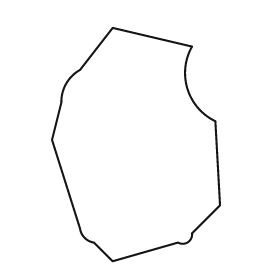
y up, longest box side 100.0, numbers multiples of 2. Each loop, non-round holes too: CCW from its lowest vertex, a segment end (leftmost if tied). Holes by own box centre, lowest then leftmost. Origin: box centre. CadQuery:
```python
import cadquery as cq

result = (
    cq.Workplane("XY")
    .moveTo(-10.0, -50.0)
    .lineTo(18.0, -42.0)
    .threePointArc((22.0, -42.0), (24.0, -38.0))
    .lineTo(36.0, -26.0)
    .lineTo(34.0, 10.0)
    .threePointArc((22.0, 24.0), (24.0, 42.0))
    .lineTo(-10.0, 50.0)
    .lineTo(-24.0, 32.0)
    .threePointArc((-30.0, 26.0), (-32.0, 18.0))
    .lineTo(-36.0, 2.0)
    .lineTo(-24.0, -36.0)
    .threePointArc((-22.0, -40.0), (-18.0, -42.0))
    .close()
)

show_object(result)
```